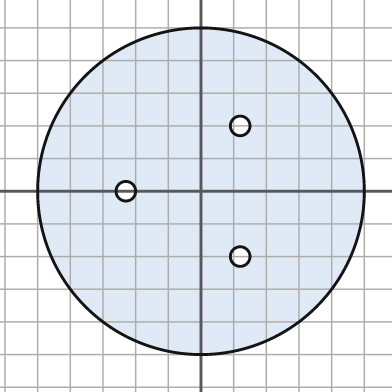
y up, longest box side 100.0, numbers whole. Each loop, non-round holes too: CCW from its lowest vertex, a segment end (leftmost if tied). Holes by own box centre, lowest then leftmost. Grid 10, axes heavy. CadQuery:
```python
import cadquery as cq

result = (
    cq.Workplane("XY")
    .moveTo(0.0, 0.0)
    .circle(50.0)
    .moveTo(12.0, -20.0)
    .circle(3.0)
    .moveTo(-23.0, 0.0)
    .circle(3.0)
    .moveTo(12.0, 20.0)
    .circle(3.0)
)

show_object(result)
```